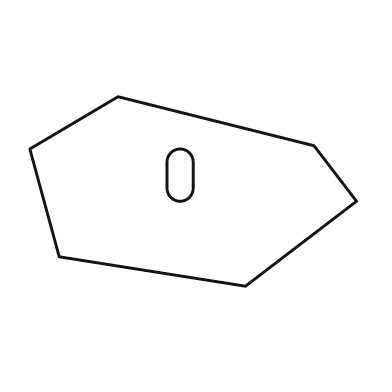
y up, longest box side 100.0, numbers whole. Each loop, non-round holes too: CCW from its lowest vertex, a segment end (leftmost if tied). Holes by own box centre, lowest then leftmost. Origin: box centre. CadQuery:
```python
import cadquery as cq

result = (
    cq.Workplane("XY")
    .moveTo(16.0, -29.0)
    .lineTo(50.0, -3.0)
    .lineTo(37.0, 14.0)
    .lineTo(-23.0, 29.0)
    .lineTo(-50.0, 13.0)
    .lineTo(-41.0, -20.0)
    .close()
    .moveTo(-8.0, 1.0)
    .threePointArc((-4.0, -3.0), (0.0, 1.0))
    .lineTo(0.0, 9.0)
    .threePointArc((-4.0, 13.0), (-8.0, 9.0))
    .close()
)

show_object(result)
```